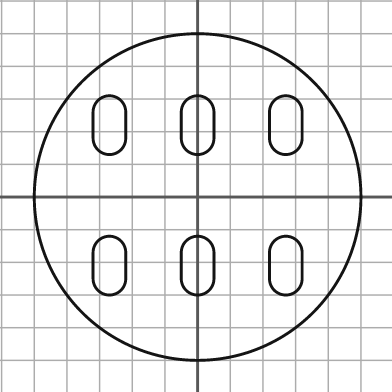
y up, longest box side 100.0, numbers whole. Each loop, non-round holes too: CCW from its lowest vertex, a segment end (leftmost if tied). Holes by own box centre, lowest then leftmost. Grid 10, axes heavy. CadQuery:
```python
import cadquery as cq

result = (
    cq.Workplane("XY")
    .moveTo(0.0, 0.0)
    .circle(50.0)
    .moveTo(-32.0, -25.0)
    .threePointArc((-27.0, -30.0), (-22.0, -25.0))
    .lineTo(-22.0, -17.0)
    .threePointArc((-27.0, -12.0), (-32.0, -17.0))
    .close()
    .moveTo(-5.0, -25.0)
    .threePointArc((0.0, -30.0), (5.0, -25.0))
    .lineTo(5.0, -17.0)
    .threePointArc((0.0, -12.0), (-5.0, -17.0))
    .close()
    .moveTo(22.0, -25.0)
    .threePointArc((27.0, -30.0), (32.0, -25.0))
    .lineTo(32.0, -17.0)
    .threePointArc((27.0, -12.0), (22.0, -17.0))
    .close()
    .moveTo(-32.0, 18.0)
    .threePointArc((-27.0, 13.0), (-22.0, 18.0))
    .lineTo(-22.0, 26.0)
    .threePointArc((-27.0, 31.0), (-32.0, 26.0))
    .close()
    .moveTo(-5.0, 18.0)
    .threePointArc((0.0, 13.0), (5.0, 18.0))
    .lineTo(5.0, 26.0)
    .threePointArc((0.0, 31.0), (-5.0, 26.0))
    .close()
    .moveTo(22.0, 18.0)
    .threePointArc((27.0, 13.0), (32.0, 18.0))
    .lineTo(32.0, 26.0)
    .threePointArc((27.0, 31.0), (22.0, 26.0))
    .close()
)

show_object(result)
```